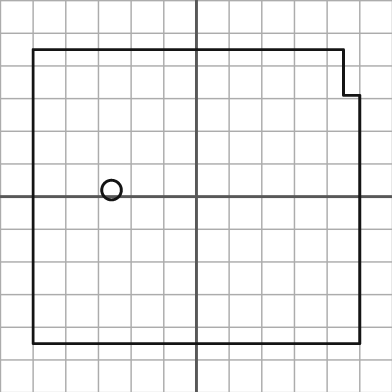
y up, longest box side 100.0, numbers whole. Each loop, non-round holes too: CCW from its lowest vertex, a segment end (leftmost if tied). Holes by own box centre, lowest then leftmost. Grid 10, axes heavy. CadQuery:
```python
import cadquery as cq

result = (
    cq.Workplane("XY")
    .moveTo(-50.0, -45.0)
    .lineTo(50.0, -45.0)
    .lineTo(50.0, 31.0)
    .lineTo(45.0, 31.0)
    .lineTo(45.0, 45.0)
    .lineTo(-50.0, 45.0)
    .close()
    .moveTo(-26.0, 2.0)
    .circle(3.0)
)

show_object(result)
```